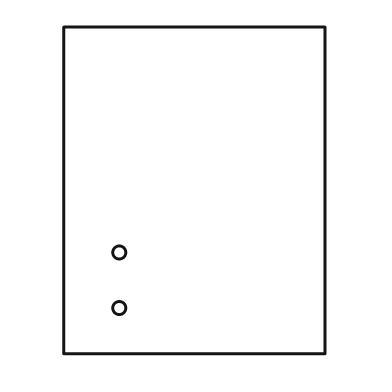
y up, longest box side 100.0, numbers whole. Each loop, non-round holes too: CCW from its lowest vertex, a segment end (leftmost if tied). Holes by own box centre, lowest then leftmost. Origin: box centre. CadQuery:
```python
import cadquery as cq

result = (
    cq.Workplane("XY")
    .moveTo(-40.0, -50.0)
    .lineTo(40.0, -50.0)
    .lineTo(40.0, 50.0)
    .lineTo(-40.0, 50.0)
    .close()
    .moveTo(-23.0, -36.0)
    .circle(2.0)
    .moveTo(-23.0, -19.0)
    .circle(2.0)
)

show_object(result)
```